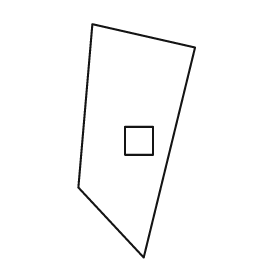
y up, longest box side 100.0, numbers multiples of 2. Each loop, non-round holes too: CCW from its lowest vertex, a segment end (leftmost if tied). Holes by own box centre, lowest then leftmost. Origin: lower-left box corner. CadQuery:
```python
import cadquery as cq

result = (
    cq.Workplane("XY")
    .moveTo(28.0, 0.0)
    .lineTo(50.0, 90.0)
    .lineTo(6.0, 100.0)
    .lineTo(0.0, 30.0)
    .close()
    .moveTo(20.0, 44.0)
    .lineTo(32.0, 44.0)
    .lineTo(32.0, 56.0)
    .lineTo(20.0, 56.0)
    .close()
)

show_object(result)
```